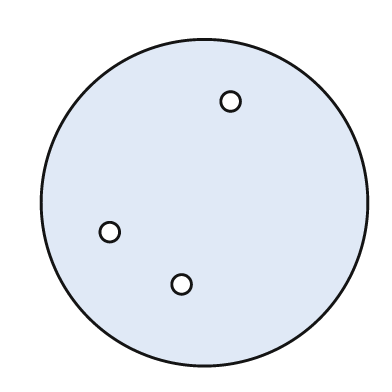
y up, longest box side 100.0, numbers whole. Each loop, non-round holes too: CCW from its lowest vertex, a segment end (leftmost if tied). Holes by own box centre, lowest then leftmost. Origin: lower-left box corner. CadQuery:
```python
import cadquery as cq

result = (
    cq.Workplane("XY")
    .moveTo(50.0, 50.0)
    .circle(50.0)
    .moveTo(43.0, 25.0)
    .circle(3.0)
    .moveTo(21.0, 41.0)
    .circle(3.0)
    .moveTo(58.0, 81.0)
    .circle(3.0)
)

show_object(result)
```